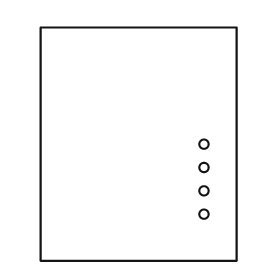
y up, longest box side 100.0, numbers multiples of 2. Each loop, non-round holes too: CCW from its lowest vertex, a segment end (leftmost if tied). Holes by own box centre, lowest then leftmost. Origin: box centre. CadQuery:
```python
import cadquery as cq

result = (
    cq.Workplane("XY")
    .moveTo(-42.0, -50.0)
    .lineTo(42.0, -50.0)
    .lineTo(42.0, 50.0)
    .lineTo(-42.0, 50.0)
    .close()
    .moveTo(28.0, -30.0)
    .circle(2.0)
    .moveTo(28.0, -20.0)
    .circle(2.0)
    .moveTo(28.0, -10.0)
    .circle(2.0)
    .moveTo(28.0, 0.0)
    .circle(2.0)
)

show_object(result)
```